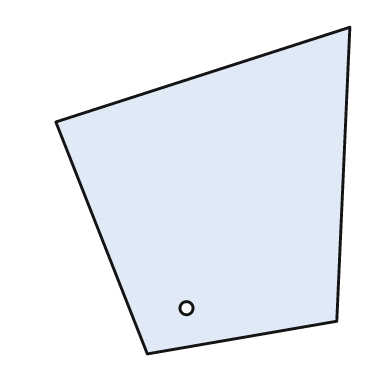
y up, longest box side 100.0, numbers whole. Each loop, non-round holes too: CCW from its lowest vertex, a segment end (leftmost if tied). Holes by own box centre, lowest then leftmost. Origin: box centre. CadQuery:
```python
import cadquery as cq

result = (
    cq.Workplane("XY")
    .moveTo(-17.0, -50.0)
    .lineTo(41.0, -40.0)
    .lineTo(45.0, 50.0)
    .lineTo(-45.0, 21.0)
    .close()
    .moveTo(-5.0, -36.0)
    .circle(2.0)
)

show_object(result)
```